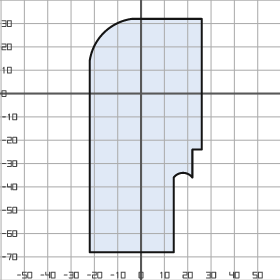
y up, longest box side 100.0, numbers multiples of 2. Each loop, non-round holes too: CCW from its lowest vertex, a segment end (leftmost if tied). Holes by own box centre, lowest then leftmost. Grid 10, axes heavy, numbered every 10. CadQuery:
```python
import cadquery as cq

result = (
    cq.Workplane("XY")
    .moveTo(-22.0, -68.0)
    .lineTo(14.0, -68.0)
    .lineTo(14.0, -36.0)
    .threePointArc((18.0, -34.0), (22.0, -36.0))
    .lineTo(22.0, -24.0)
    .lineTo(26.0, -24.0)
    .lineTo(26.0, 32.0)
    .lineTo(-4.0, 32.0)
    .threePointArc((-16.0, 26.0), (-22.0, 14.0))
    .close()
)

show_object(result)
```